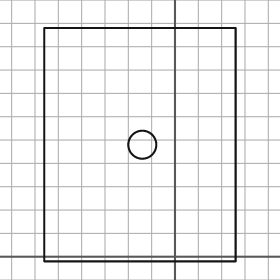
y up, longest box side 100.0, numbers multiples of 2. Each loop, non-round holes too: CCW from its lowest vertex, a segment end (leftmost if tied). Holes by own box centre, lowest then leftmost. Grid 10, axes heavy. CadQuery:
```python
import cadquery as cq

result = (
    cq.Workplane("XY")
    .moveTo(-56.0, -2.0)
    .lineTo(26.0, -2.0)
    .lineTo(26.0, 98.0)
    .lineTo(-56.0, 98.0)
    .close()
    .moveTo(-14.0, 48.0)
    .circle(6.0)
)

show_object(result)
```